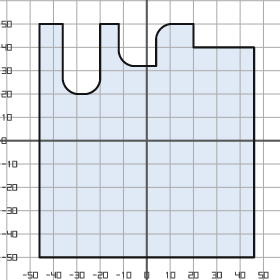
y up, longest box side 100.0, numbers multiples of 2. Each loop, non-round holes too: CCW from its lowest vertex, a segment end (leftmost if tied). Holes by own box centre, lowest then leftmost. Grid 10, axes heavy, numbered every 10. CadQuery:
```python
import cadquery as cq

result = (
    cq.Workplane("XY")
    .moveTo(-46.0, -50.0)
    .lineTo(46.0, -50.0)
    .lineTo(46.0, 40.0)
    .lineTo(20.0, 40.0)
    .lineTo(20.0, 50.0)
    .lineTo(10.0, 50.0)
    .threePointArc((6.0, 48.0), (4.0, 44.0))
    .lineTo(4.0, 32.0)
    .lineTo(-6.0, 32.0)
    .threePointArc((-10.0, 34.0), (-12.0, 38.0))
    .lineTo(-12.0, 50.0)
    .lineTo(-20.0, 50.0)
    .lineTo(-20.0, 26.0)
    .threePointArc((-22.0, 22.0), (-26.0, 20.0))
    .lineTo(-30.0, 20.0)
    .threePointArc((-34.0, 22.0), (-36.0, 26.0))
    .lineTo(-36.0, 50.0)
    .lineTo(-46.0, 50.0)
    .close()
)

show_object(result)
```